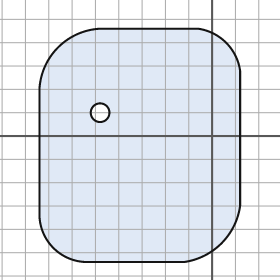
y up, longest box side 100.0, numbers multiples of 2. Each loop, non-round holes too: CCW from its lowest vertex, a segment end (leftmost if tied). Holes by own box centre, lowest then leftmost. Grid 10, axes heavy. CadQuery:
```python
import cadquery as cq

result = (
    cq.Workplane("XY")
    .moveTo(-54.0, -54.0)
    .lineTo(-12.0, -54.0)
    .threePointArc((4.0, -46.0), (12.0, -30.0))
    .lineTo(12.0, 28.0)
    .threePointArc((6.0, 40.0), (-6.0, 46.0))
    .lineTo(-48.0, 46.0)
    .threePointArc((-66.0, 38.0), (-74.0, 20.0))
    .lineTo(-74.0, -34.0)
    .threePointArc((-68.0, -48.0), (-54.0, -54.0))
    .close()
    .moveTo(-48.0, 10.0)
    .circle(4.0)
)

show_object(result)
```